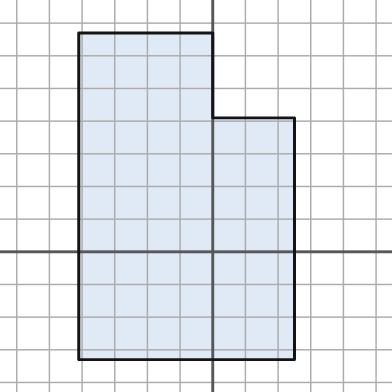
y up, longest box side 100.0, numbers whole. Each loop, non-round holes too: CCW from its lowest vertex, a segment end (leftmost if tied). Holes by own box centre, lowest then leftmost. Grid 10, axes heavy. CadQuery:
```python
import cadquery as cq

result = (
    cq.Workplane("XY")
    .moveTo(-41.0, -33.0)
    .lineTo(25.0, -33.0)
    .lineTo(25.0, 41.0)
    .lineTo(0.0, 41.0)
    .lineTo(0.0, 67.0)
    .lineTo(-41.0, 67.0)
    .close()
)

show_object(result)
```